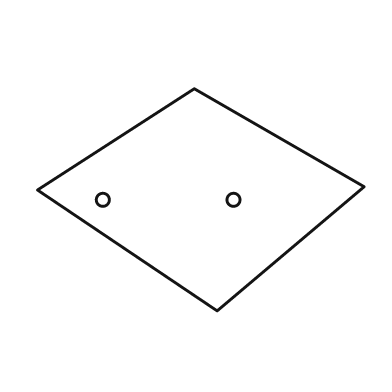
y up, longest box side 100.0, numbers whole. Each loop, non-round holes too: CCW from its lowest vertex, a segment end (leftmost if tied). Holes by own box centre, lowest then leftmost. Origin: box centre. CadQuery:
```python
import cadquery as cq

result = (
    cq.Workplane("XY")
    .moveTo(5.0, -34.0)
    .lineTo(50.0, 4.0)
    .lineTo(-2.0, 34.0)
    .lineTo(-50.0, 3.0)
    .close()
    .moveTo(-30.0, 0.0)
    .circle(2.0)
    .moveTo(10.0, 0.0)
    .circle(2.0)
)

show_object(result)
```